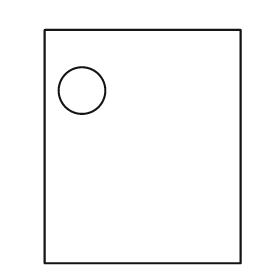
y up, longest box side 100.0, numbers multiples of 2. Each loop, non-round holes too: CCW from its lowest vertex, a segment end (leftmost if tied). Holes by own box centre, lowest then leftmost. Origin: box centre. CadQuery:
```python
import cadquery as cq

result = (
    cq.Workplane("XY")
    .moveTo(-42.0, -50.0)
    .lineTo(42.0, -50.0)
    .lineTo(42.0, 50.0)
    .lineTo(-42.0, 50.0)
    .close()
    .moveTo(-26.0, 24.0)
    .circle(10.0)
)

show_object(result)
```